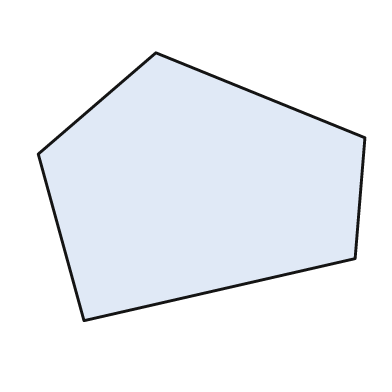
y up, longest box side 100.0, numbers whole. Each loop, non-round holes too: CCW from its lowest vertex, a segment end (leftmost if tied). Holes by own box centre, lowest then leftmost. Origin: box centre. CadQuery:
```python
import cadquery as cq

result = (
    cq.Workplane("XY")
    .moveTo(-36.0, -41.0)
    .lineTo(47.0, -22.0)
    .lineTo(50.0, 15.0)
    .lineTo(-14.0, 41.0)
    .lineTo(-50.0, 10.0)
    .close()
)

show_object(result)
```